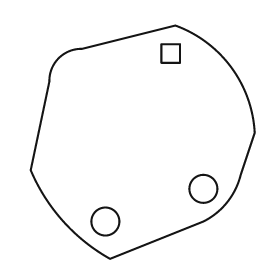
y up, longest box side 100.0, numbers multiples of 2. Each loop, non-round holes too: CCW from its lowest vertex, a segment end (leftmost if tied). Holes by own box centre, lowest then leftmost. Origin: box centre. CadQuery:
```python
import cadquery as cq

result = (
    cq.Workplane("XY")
    .moveTo(-14.0, -50.0)
    .lineTo(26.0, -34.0)
    .threePointArc((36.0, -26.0), (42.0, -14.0))
    .lineTo(48.0, 4.0)
    .threePointArc((38.0, 32.0), (14.0, 50.0))
    .lineTo(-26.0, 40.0)
    .threePointArc((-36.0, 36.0), (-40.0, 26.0))
    .lineTo(-48.0, -12.0)
    .threePointArc((-34.0, -34.0), (-14.0, -50.0))
    .close()
    .moveTo(-16.0, -34.0)
    .circle(6.0)
    .moveTo(26.0, -20.0)
    .circle(6.0)
    .moveTo(8.0, 34.0)
    .lineTo(16.0, 34.0)
    .lineTo(16.0, 42.0)
    .lineTo(8.0, 42.0)
    .close()
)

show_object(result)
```